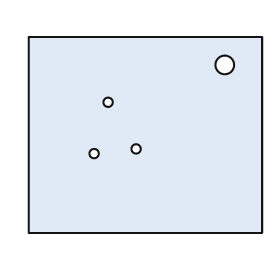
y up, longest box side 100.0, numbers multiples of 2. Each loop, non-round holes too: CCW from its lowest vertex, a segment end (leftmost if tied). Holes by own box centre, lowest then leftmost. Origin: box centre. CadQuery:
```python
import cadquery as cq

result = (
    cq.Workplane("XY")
    .moveTo(-50.0, -42.0)
    .lineTo(50.0, -42.0)
    .lineTo(50.0, 42.0)
    .lineTo(-50.0, 42.0)
    .close()
    .moveTo(-22.0, -8.0)
    .circle(2.0)
    .moveTo(-4.0, -6.0)
    .circle(2.0)
    .moveTo(-16.0, 14.0)
    .circle(2.0)
    .moveTo(34.0, 30.0)
    .circle(4.0)
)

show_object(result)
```